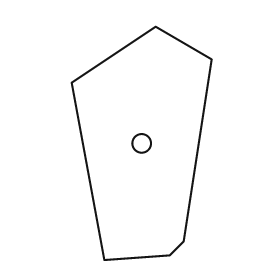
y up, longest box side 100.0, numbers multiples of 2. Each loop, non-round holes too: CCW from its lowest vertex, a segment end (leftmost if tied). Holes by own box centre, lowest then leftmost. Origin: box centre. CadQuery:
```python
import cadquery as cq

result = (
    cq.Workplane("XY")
    .moveTo(-16.0, -50.0)
    .lineTo(12.0, -48.0)
    .lineTo(18.0, -42.0)
    .lineTo(30.0, 36.0)
    .lineTo(6.0, 50.0)
    .lineTo(-30.0, 26.0)
    .close()
    .moveTo(0.0, 0.0)
    .circle(4.0)
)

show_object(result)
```